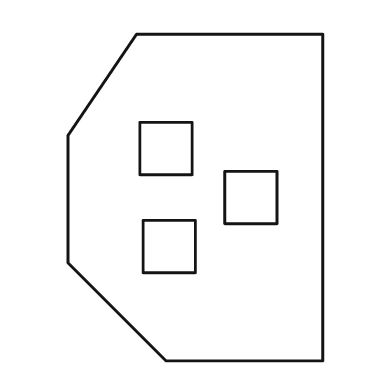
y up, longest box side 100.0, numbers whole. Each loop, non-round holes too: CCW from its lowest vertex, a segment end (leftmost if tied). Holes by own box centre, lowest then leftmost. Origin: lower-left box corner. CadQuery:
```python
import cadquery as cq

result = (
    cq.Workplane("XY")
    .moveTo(30.0, 0.0)
    .lineTo(78.0, 0.0)
    .lineTo(78.0, 100.0)
    .lineTo(21.0, 100.0)
    .lineTo(0.0, 69.0)
    .lineTo(0.0, 30.0)
    .close()
    .moveTo(23.0, 27.0)
    .lineTo(39.0, 27.0)
    .lineTo(39.0, 43.0)
    .lineTo(23.0, 43.0)
    .close()
    .moveTo(48.0, 42.0)
    .lineTo(64.0, 42.0)
    .lineTo(64.0, 58.0)
    .lineTo(48.0, 58.0)
    .close()
    .moveTo(22.0, 57.0)
    .lineTo(38.0, 57.0)
    .lineTo(38.0, 73.0)
    .lineTo(22.0, 73.0)
    .close()
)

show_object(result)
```